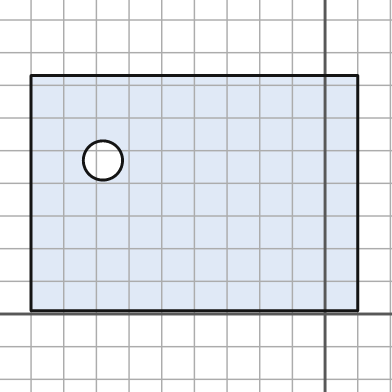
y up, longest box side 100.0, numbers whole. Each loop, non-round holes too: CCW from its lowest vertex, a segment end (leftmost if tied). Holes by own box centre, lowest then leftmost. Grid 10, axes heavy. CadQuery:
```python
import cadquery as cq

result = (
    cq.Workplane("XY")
    .moveTo(-90.0, 1.0)
    .lineTo(10.0, 1.0)
    .lineTo(10.0, 73.0)
    .lineTo(-90.0, 73.0)
    .close()
    .moveTo(-68.0, 47.0)
    .circle(6.0)
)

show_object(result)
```